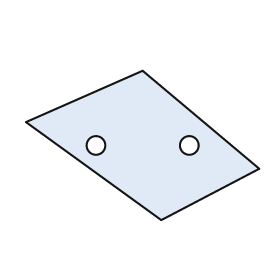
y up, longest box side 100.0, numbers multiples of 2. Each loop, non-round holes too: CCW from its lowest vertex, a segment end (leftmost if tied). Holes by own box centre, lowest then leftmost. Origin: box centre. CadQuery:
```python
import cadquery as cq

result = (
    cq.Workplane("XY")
    .moveTo(8.0, -32.0)
    .lineTo(50.0, -10.0)
    .lineTo(0.0, 32.0)
    .lineTo(-50.0, 10.0)
    .close()
    .moveTo(-20.0, 0.0)
    .circle(4.0)
    .moveTo(20.0, 0.0)
    .circle(4.0)
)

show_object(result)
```